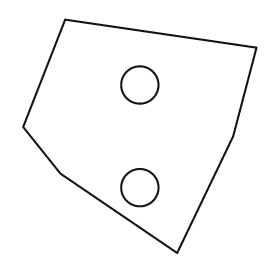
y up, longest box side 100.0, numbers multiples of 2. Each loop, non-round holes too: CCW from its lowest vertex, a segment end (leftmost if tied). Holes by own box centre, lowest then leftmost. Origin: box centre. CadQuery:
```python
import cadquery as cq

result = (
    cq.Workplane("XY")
    .moveTo(16.0, -50.0)
    .lineTo(40.0, 0.0)
    .lineTo(50.0, 38.0)
    .lineTo(-32.0, 50.0)
    .lineTo(-50.0, 4.0)
    .lineTo(-34.0, -16.0)
    .close()
    .moveTo(0.0, -22.0)
    .circle(8.0)
    .moveTo(0.0, 22.0)
    .circle(8.0)
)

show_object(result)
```